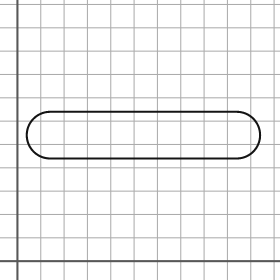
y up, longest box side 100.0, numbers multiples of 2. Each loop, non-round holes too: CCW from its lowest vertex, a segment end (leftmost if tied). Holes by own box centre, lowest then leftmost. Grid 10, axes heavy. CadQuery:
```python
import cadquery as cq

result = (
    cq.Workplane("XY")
    .moveTo(14.0, 44.0)
    .lineTo(94.0, 44.0)
    .threePointArc((104.0, 54.0), (94.0, 64.0))
    .lineTo(14.0, 64.0)
    .threePointArc((4.0, 54.0), (14.0, 44.0))
    .close()
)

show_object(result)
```